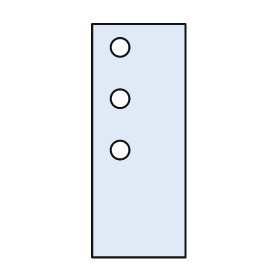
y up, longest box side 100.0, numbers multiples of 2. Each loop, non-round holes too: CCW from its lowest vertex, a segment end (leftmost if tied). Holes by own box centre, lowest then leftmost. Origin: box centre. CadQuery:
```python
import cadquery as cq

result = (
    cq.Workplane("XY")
    .moveTo(-20.0, -50.0)
    .lineTo(20.0, -50.0)
    .lineTo(20.0, 50.0)
    .lineTo(-20.0, 50.0)
    .close()
    .moveTo(-8.0, -4.0)
    .circle(4.0)
    .moveTo(-8.0, 18.0)
    .circle(4.0)
    .moveTo(-8.0, 40.0)
    .circle(4.0)
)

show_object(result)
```